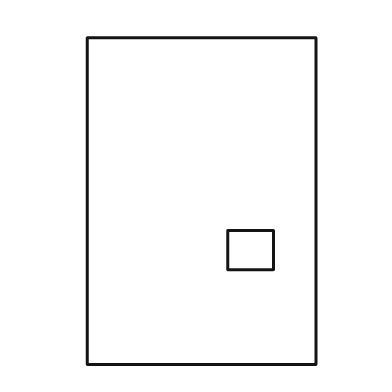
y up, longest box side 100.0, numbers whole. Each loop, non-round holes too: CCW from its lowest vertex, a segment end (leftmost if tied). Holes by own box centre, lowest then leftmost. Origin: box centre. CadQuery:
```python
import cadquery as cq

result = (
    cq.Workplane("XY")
    .moveTo(-35.0, -50.0)
    .lineTo(35.0, -50.0)
    .lineTo(35.0, 50.0)
    .lineTo(-35.0, 50.0)
    .close()
    .moveTo(8.0, -21.0)
    .lineTo(22.0, -21.0)
    .lineTo(22.0, -9.0)
    .lineTo(8.0, -9.0)
    .close()
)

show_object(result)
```